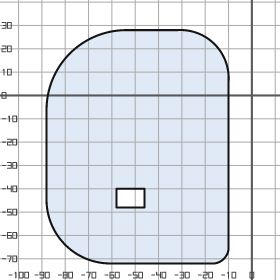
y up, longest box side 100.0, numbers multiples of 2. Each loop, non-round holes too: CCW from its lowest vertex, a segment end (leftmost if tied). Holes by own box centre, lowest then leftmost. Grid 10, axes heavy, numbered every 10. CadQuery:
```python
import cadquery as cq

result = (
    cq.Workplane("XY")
    .moveTo(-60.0, -72.0)
    .lineTo(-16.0, -72.0)
    .threePointArc((-12.0, -70.0), (-10.0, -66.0))
    .lineTo(-10.0, 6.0)
    .threePointArc((-16.0, 22.0), (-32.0, 28.0))
    .lineTo(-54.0, 28.0)
    .threePointArc((-78.0, 18.0), (-88.0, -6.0))
    .lineTo(-88.0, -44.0)
    .threePointArc((-80.0, -64.0), (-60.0, -72.0))
    .close()
    .moveTo(-58.0, -48.0)
    .lineTo(-46.0, -48.0)
    .lineTo(-46.0, -40.0)
    .lineTo(-58.0, -40.0)
    .close()
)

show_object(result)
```